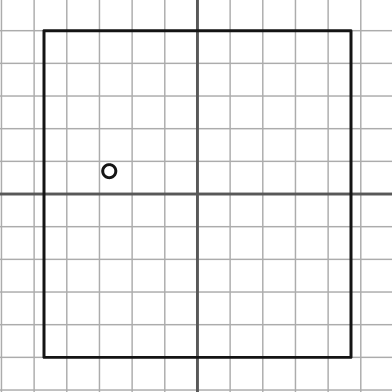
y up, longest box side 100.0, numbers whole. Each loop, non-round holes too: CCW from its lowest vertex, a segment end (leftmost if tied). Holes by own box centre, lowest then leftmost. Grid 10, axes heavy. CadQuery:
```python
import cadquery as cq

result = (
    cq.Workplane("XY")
    .moveTo(-47.0, -50.0)
    .lineTo(47.0, -50.0)
    .lineTo(47.0, 50.0)
    .lineTo(-47.0, 50.0)
    .close()
    .moveTo(-27.0, 7.0)
    .circle(2.0)
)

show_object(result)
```